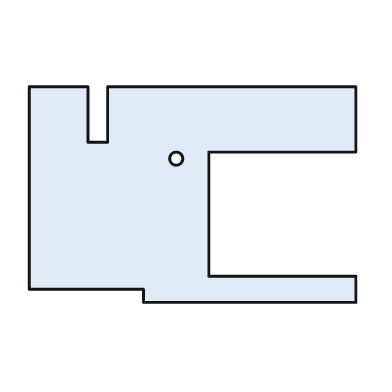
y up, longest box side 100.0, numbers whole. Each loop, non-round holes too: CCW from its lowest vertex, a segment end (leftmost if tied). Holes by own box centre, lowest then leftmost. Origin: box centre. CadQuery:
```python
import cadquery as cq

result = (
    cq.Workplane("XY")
    .moveTo(-15.0, -33.0)
    .lineTo(50.0, -33.0)
    .lineTo(50.0, -25.0)
    .lineTo(5.0, -25.0)
    .lineTo(5.0, 13.0)
    .lineTo(50.0, 13.0)
    .lineTo(50.0, 33.0)
    .lineTo(-26.0, 33.0)
    .lineTo(-26.0, 16.0)
    .lineTo(-32.0, 16.0)
    .lineTo(-32.0, 33.0)
    .lineTo(-50.0, 33.0)
    .lineTo(-50.0, -29.0)
    .lineTo(-15.0, -29.0)
    .close()
    .moveTo(-5.0, 11.0)
    .circle(2.0)
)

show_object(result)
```